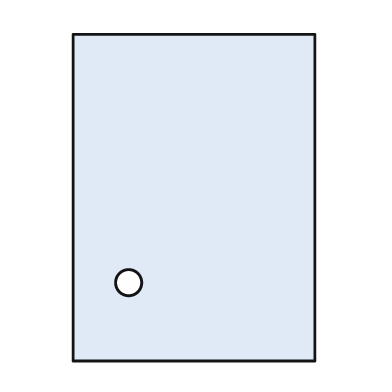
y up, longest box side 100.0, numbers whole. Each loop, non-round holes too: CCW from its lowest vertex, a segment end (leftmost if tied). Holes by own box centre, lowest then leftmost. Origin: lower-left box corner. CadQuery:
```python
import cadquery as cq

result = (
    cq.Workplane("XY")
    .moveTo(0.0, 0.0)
    .lineTo(74.0, 0.0)
    .lineTo(74.0, 100.0)
    .lineTo(0.0, 100.0)
    .close()
    .moveTo(17.0, 24.0)
    .circle(4.0)
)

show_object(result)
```